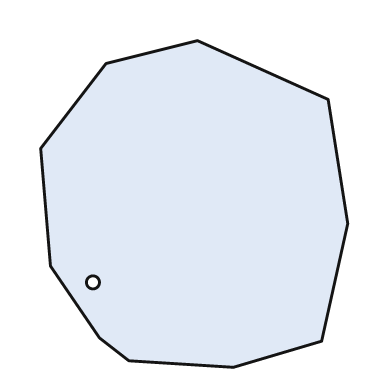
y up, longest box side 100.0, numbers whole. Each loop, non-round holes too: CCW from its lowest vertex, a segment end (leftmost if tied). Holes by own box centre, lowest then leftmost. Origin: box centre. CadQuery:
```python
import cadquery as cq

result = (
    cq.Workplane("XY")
    .moveTo(12.0, -50.0)
    .lineTo(39.0, -42.0)
    .lineTo(47.0, -6.0)
    .lineTo(41.0, 32.0)
    .lineTo(1.0, 50.0)
    .lineTo(-27.0, 43.0)
    .lineTo(-47.0, 17.0)
    .lineTo(-44.0, -19.0)
    .lineTo(-29.0, -41.0)
    .lineTo(-20.0, -48.0)
    .close()
    .moveTo(-31.0, -24.0)
    .circle(2.0)
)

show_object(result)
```